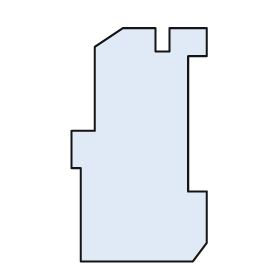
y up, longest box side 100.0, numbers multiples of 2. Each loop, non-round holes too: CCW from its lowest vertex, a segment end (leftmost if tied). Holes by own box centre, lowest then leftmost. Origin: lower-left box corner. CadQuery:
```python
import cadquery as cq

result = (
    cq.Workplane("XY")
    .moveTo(4.0, 0.0)
    .lineTo(52.0, 0.0)
    .lineTo(58.0, 8.0)
    .lineTo(58.0, 30.0)
    .lineTo(50.0, 30.0)
    .lineTo(50.0, 88.0)
    .lineTo(58.0, 88.0)
    .lineTo(58.0, 100.0)
    .lineTo(42.0, 100.0)
    .lineTo(42.0, 90.0)
    .lineTo(36.0, 90.0)
    .lineTo(36.0, 100.0)
    .lineTo(22.0, 100.0)
    .lineTo(10.0, 92.0)
    .lineTo(10.0, 56.0)
    .lineTo(0.0, 56.0)
    .lineTo(0.0, 40.0)
    .lineTo(4.0, 40.0)
    .close()
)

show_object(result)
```